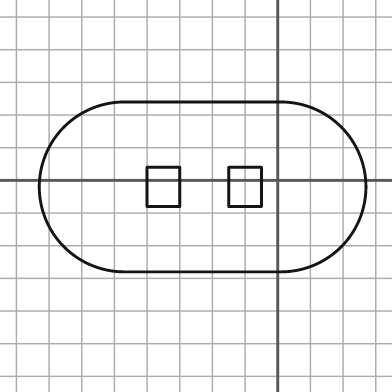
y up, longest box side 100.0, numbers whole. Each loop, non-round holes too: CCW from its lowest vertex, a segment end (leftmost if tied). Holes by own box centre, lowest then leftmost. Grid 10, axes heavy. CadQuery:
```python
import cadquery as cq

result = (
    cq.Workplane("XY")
    .moveTo(-47.0, -28.0)
    .lineTo(1.0, -28.0)
    .threePointArc((27.0, -2.0), (1.0, 24.0))
    .lineTo(-47.0, 24.0)
    .threePointArc((-73.0, -2.0), (-47.0, -28.0))
    .close()
    .moveTo(-40.0, -8.0)
    .lineTo(-30.0, -8.0)
    .lineTo(-30.0, 4.0)
    .lineTo(-40.0, 4.0)
    .close()
    .moveTo(-15.0, -8.0)
    .lineTo(-5.0, -8.0)
    .lineTo(-5.0, 4.0)
    .lineTo(-15.0, 4.0)
    .close()
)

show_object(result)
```